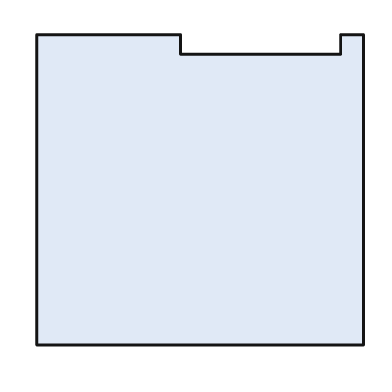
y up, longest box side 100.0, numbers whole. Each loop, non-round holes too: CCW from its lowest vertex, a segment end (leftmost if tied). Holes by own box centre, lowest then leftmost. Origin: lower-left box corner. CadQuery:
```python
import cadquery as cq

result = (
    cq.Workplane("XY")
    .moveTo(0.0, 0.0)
    .lineTo(100.0, 0.0)
    .lineTo(100.0, 95.0)
    .lineTo(93.0, 95.0)
    .lineTo(93.0, 89.0)
    .lineTo(44.0, 89.0)
    .lineTo(44.0, 95.0)
    .lineTo(0.0, 95.0)
    .close()
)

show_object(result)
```